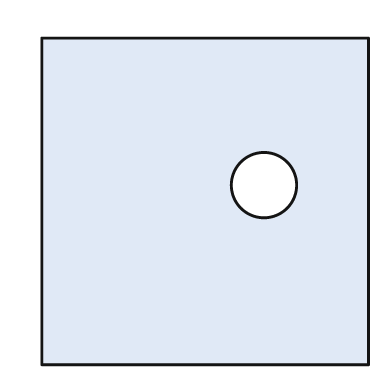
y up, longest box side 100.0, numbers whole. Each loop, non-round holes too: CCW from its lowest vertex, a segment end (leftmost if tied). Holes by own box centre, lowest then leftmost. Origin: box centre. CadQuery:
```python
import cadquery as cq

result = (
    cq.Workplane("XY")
    .moveTo(-50.0, -50.0)
    .lineTo(50.0, -50.0)
    .lineTo(50.0, 50.0)
    .lineTo(-50.0, 50.0)
    .close()
    .moveTo(18.0, 5.0)
    .circle(10.0)
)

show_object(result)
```